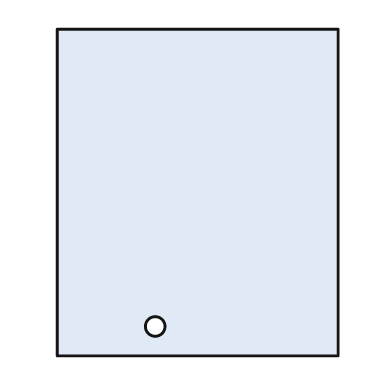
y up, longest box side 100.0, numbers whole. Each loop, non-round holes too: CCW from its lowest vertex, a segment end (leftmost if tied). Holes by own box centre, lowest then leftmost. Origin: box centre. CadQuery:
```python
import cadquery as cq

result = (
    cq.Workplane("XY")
    .moveTo(-43.0, -50.0)
    .lineTo(43.0, -50.0)
    .lineTo(43.0, 50.0)
    .lineTo(-43.0, 50.0)
    .close()
    .moveTo(-13.0, -41.0)
    .circle(3.0)
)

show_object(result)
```